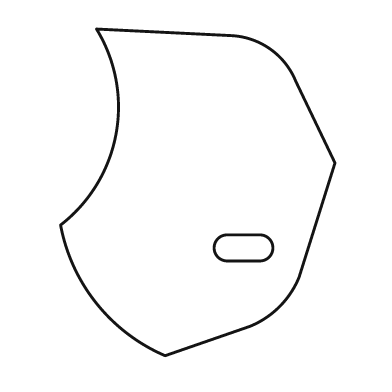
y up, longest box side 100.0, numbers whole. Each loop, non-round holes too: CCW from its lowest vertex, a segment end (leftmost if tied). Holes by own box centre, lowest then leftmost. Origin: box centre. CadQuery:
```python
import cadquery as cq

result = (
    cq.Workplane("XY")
    .moveTo(-10.0, -50.0)
    .lineTo(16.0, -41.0)
    .threePointArc((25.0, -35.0), (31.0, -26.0))
    .lineTo(42.0, 9.0)
    .lineTo(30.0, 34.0)
    .threePointArc((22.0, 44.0), (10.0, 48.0))
    .lineTo(-31.0, 50.0)
    .threePointArc((-25.0, 18.0), (-42.0, -10.0))
    .threePointArc((-31.0, -34.0), (-10.0, -50.0))
    .close()
    .moveTo(9.0, -21.0)
    .lineTo(19.0, -21.0)
    .threePointArc((23.0, -17.0), (19.0, -13.0))
    .lineTo(9.0, -13.0)
    .threePointArc((5.0, -17.0), (9.0, -21.0))
    .close()
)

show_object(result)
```